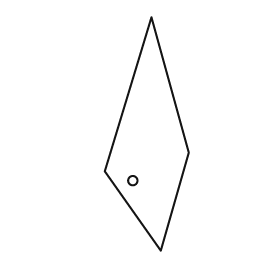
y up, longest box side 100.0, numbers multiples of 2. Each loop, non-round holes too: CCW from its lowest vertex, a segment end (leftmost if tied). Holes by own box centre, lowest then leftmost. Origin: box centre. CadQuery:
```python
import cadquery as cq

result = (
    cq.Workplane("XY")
    .moveTo(6.0, -50.0)
    .lineTo(18.0, -8.0)
    .lineTo(2.0, 50.0)
    .lineTo(-18.0, -16.0)
    .close()
    .moveTo(-6.0, -20.0)
    .circle(2.0)
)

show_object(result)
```